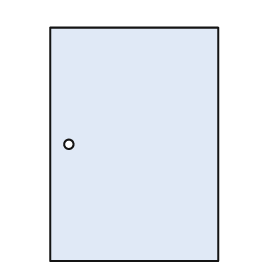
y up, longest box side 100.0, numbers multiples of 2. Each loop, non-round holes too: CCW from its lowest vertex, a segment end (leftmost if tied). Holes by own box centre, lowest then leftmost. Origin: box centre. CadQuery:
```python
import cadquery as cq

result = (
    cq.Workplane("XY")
    .moveTo(-36.0, -50.0)
    .lineTo(36.0, -50.0)
    .lineTo(36.0, 50.0)
    .lineTo(-36.0, 50.0)
    .close()
    .moveTo(-28.0, 0.0)
    .circle(2.0)
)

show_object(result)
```